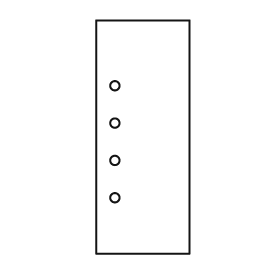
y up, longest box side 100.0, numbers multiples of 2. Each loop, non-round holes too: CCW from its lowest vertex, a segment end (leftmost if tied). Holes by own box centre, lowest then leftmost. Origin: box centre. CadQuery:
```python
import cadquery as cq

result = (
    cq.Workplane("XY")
    .moveTo(-20.0, -50.0)
    .lineTo(20.0, -50.0)
    .lineTo(20.0, 50.0)
    .lineTo(-20.0, 50.0)
    .close()
    .moveTo(-12.0, -26.0)
    .circle(2.0)
    .moveTo(-12.0, -10.0)
    .circle(2.0)
    .moveTo(-12.0, 6.0)
    .circle(2.0)
    .moveTo(-12.0, 22.0)
    .circle(2.0)
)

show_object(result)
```